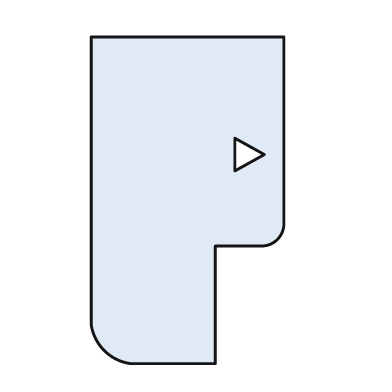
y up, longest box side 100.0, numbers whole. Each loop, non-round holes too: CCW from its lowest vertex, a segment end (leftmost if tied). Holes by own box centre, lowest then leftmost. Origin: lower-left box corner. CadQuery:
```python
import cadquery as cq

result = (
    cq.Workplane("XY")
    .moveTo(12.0, 0.0)
    .lineTo(38.0, 0.0)
    .lineTo(38.0, 36.0)
    .lineTo(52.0, 36.0)
    .threePointArc((57.0, 38.0), (59.0, 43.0))
    .lineTo(59.0, 100.0)
    .lineTo(0.0, 100.0)
    .lineTo(0.0, 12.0)
    .threePointArc((4.0, 4.0), (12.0, 0.0))
    .close()
    .moveTo(44.0, 59.0)
    .lineTo(53.0, 64.0)
    .lineTo(44.0, 69.0)
    .close()
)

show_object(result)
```